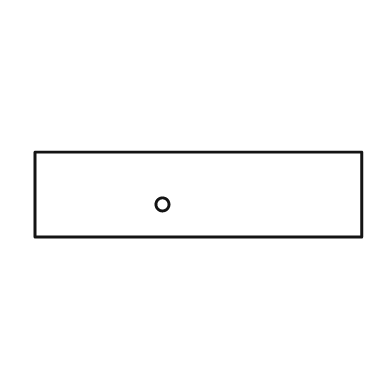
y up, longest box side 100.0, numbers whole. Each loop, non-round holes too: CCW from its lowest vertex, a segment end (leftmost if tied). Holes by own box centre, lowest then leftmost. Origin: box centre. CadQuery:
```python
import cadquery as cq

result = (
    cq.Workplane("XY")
    .moveTo(-50.0, -13.0)
    .lineTo(50.0, -13.0)
    .lineTo(50.0, 13.0)
    .lineTo(-50.0, 13.0)
    .close()
    .moveTo(-11.0, -3.0)
    .circle(2.0)
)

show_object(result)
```